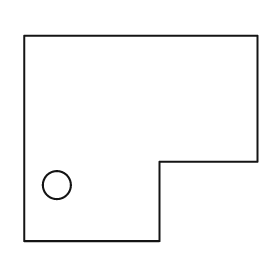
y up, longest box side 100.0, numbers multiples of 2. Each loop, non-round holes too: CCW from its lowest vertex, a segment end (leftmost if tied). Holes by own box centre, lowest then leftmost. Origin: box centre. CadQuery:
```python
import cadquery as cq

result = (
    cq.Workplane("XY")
    .moveTo(-50.0, -44.0)
    .lineTo(8.0, -44.0)
    .lineTo(8.0, -10.0)
    .lineTo(50.0, -10.0)
    .lineTo(50.0, 44.0)
    .lineTo(-50.0, 44.0)
    .close()
    .moveTo(-36.0, -20.0)
    .circle(6.0)
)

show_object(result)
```